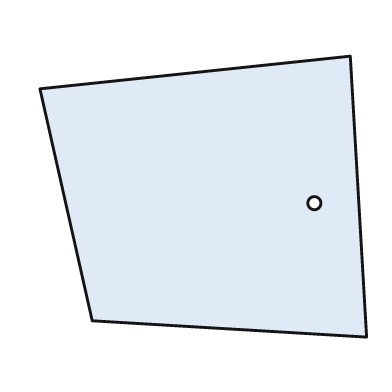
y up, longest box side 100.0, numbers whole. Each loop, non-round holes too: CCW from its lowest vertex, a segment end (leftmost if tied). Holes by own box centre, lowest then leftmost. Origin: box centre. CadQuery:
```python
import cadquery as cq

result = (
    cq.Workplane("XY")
    .moveTo(50.0, -43.0)
    .lineTo(45.0, 43.0)
    .lineTo(-50.0, 33.0)
    .lineTo(-34.0, -38.0)
    .close()
    .moveTo(34.0, -2.0)
    .circle(2.0)
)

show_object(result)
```